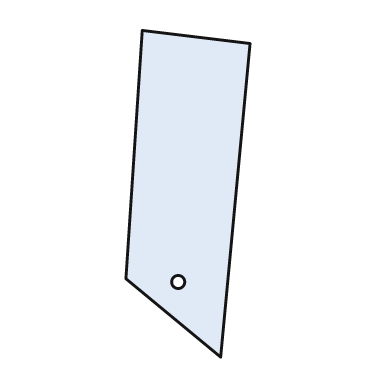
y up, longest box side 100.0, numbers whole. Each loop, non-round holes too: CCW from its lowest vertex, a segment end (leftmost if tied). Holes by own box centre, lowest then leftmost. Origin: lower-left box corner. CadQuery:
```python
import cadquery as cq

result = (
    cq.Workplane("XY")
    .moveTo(29.0, 0.0)
    .lineTo(38.0, 96.0)
    .lineTo(5.0, 100.0)
    .lineTo(0.0, 24.0)
    .close()
    .moveTo(16.0, 23.0)
    .circle(2.0)
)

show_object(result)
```